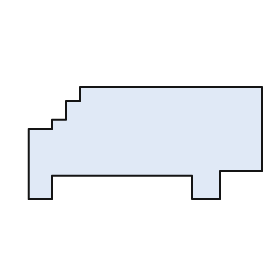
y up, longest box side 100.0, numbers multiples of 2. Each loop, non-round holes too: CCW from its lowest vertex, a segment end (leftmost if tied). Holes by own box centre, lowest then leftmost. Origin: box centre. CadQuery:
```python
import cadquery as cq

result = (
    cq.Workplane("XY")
    .moveTo(-50.0, -24.0)
    .lineTo(-40.0, -24.0)
    .lineTo(-40.0, -14.0)
    .lineTo(20.0, -14.0)
    .lineTo(20.0, -24.0)
    .lineTo(32.0, -24.0)
    .lineTo(32.0, -12.0)
    .lineTo(50.0, -12.0)
    .lineTo(50.0, 24.0)
    .lineTo(-28.0, 24.0)
    .lineTo(-28.0, 18.0)
    .lineTo(-34.0, 18.0)
    .lineTo(-34.0, 10.0)
    .lineTo(-40.0, 10.0)
    .lineTo(-40.0, 6.0)
    .lineTo(-50.0, 6.0)
    .close()
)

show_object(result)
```